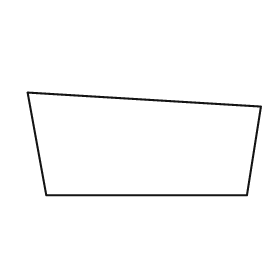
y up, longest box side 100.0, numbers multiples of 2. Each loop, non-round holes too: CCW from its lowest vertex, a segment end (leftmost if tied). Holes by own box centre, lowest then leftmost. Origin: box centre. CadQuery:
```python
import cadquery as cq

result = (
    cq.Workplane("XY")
    .moveTo(-42.0, -22.0)
    .lineTo(44.0, -22.0)
    .lineTo(50.0, 16.0)
    .lineTo(-50.0, 22.0)
    .close()
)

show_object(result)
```